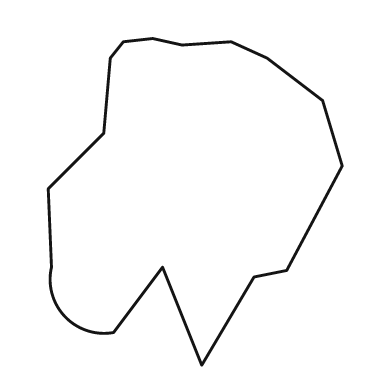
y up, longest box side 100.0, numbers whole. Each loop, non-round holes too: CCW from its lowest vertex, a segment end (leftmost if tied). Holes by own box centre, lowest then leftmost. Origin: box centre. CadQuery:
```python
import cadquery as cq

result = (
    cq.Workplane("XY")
    .moveTo(2.0, -50.0)
    .lineTo(18.0, -23.0)
    .lineTo(28.0, -21.0)
    .lineTo(45.0, 11.0)
    .lineTo(39.0, 31.0)
    .lineTo(22.0, 44.0)
    .lineTo(11.0, 49.0)
    .lineTo(-4.0, 48.0)
    .lineTo(-13.0, 50.0)
    .lineTo(-22.0, 49.0)
    .lineTo(-26.0, 44.0)
    .lineTo(-28.0, 21.0)
    .lineTo(-45.0, 4.0)
    .lineTo(-44.0, -20.0)
    .threePointArc((-40.0, -35.0), (-25.0, -40.0))
    .lineTo(-10.0, -20.0)
    .close()
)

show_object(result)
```